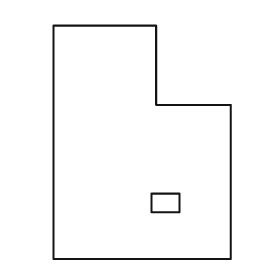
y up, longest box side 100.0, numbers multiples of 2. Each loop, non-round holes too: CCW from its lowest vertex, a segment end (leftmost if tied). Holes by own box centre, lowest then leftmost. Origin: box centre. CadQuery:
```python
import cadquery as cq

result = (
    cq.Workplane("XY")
    .moveTo(-38.0, -50.0)
    .lineTo(38.0, -50.0)
    .lineTo(38.0, 16.0)
    .lineTo(6.0, 16.0)
    .lineTo(6.0, 50.0)
    .lineTo(-38.0, 50.0)
    .close()
    .moveTo(4.0, -30.0)
    .lineTo(16.0, -30.0)
    .lineTo(16.0, -22.0)
    .lineTo(4.0, -22.0)
    .close()
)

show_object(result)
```